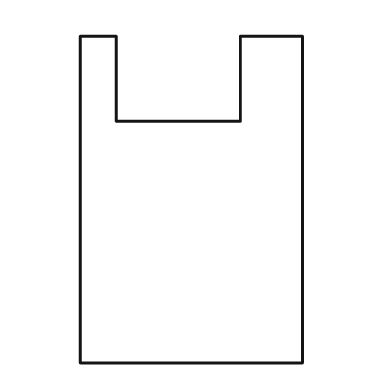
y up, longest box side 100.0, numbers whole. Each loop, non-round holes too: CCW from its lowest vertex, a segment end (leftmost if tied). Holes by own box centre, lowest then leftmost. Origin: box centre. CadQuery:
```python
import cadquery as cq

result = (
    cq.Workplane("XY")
    .moveTo(-34.0, -50.0)
    .lineTo(34.0, -50.0)
    .lineTo(34.0, 50.0)
    .lineTo(15.0, 50.0)
    .lineTo(15.0, 24.0)
    .lineTo(-23.0, 24.0)
    .lineTo(-23.0, 50.0)
    .lineTo(-34.0, 50.0)
    .close()
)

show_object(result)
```